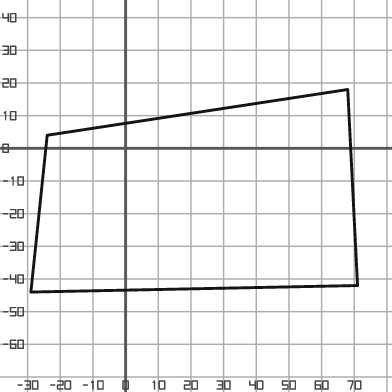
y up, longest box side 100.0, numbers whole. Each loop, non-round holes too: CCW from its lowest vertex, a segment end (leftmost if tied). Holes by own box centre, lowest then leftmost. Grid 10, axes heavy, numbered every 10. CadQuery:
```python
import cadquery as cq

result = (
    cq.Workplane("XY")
    .moveTo(-29.0, -44.0)
    .lineTo(71.0, -42.0)
    .lineTo(68.0, 18.0)
    .lineTo(-24.0, 4.0)
    .close()
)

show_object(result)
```